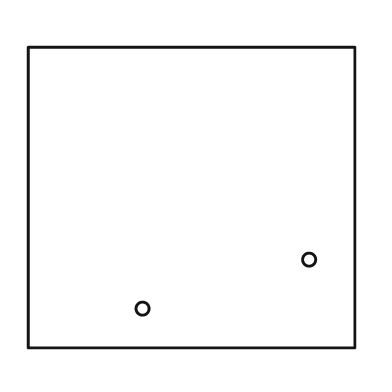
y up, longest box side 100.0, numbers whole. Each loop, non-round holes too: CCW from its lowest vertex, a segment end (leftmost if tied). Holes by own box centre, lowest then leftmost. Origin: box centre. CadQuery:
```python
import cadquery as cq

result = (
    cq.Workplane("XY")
    .moveTo(-50.0, -46.0)
    .lineTo(50.0, -46.0)
    .lineTo(50.0, 46.0)
    .lineTo(-50.0, 46.0)
    .close()
    .moveTo(-15.0, -34.0)
    .circle(2.0)
    .moveTo(36.0, -19.0)
    .circle(2.0)
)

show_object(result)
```